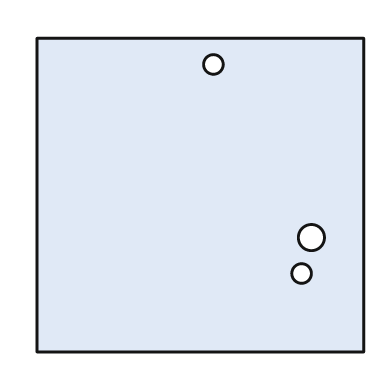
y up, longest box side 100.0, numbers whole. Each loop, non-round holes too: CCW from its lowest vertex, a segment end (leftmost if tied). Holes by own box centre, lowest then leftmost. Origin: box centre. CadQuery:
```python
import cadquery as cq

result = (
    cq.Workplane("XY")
    .moveTo(-50.0, -48.0)
    .lineTo(50.0, -48.0)
    .lineTo(50.0, 48.0)
    .lineTo(-50.0, 48.0)
    .close()
    .moveTo(31.0, -24.0)
    .circle(3.0)
    .moveTo(34.0, -13.0)
    .circle(4.0)
    .moveTo(4.0, 40.0)
    .circle(3.0)
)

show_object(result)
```